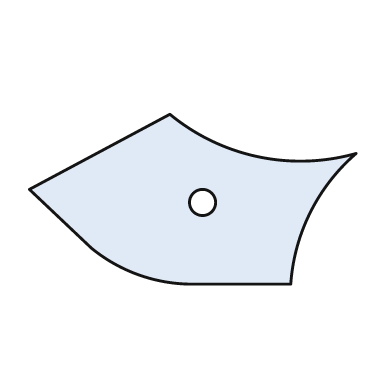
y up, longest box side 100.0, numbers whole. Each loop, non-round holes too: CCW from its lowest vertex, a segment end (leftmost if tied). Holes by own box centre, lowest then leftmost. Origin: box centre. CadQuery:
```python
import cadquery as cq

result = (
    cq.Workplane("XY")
    .moveTo(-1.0, -26.0)
    .lineTo(30.0, -26.0)
    .threePointArc((36.0, -4.0), (50.0, 14.0))
    .threePointArc((20.0, 13.0), (-7.0, 26.0))
    .lineTo(-50.0, 3.0)
    .lineTo(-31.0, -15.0)
    .threePointArc((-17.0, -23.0), (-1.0, -26.0))
    .close()
    .moveTo(3.0, -1.0)
    .circle(4.0)
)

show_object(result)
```